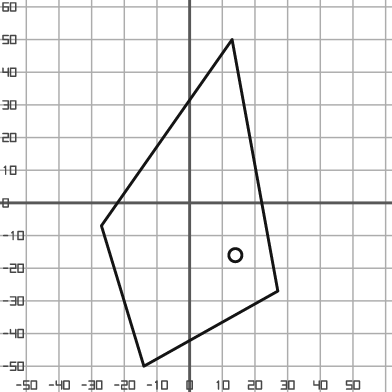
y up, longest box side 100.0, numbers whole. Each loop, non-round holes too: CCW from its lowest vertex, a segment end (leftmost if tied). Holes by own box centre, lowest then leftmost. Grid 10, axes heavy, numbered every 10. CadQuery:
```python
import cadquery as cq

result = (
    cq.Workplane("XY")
    .moveTo(-14.0, -50.0)
    .lineTo(27.0, -27.0)
    .lineTo(13.0, 50.0)
    .lineTo(-27.0, -7.0)
    .close()
    .moveTo(14.0, -16.0)
    .circle(2.0)
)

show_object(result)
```